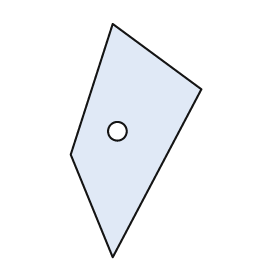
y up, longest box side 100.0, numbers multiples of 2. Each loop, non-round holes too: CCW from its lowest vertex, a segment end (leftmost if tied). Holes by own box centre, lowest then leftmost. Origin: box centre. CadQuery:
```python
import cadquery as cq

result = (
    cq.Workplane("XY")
    .moveTo(-10.0, -50.0)
    .lineTo(28.0, 22.0)
    .lineTo(-10.0, 50.0)
    .lineTo(-28.0, -6.0)
    .close()
    .moveTo(-8.0, 4.0)
    .circle(4.0)
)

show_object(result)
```